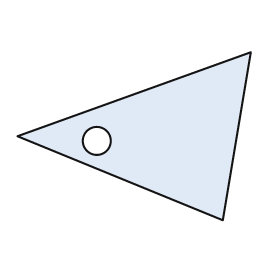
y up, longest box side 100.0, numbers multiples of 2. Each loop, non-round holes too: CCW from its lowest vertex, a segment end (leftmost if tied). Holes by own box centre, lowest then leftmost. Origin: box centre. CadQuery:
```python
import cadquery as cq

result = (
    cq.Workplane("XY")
    .moveTo(38.0, -36.0)
    .lineTo(50.0, 36.0)
    .lineTo(-50.0, 0.0)
    .close()
    .moveTo(-16.0, -2.0)
    .circle(6.0)
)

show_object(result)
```